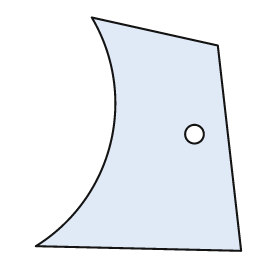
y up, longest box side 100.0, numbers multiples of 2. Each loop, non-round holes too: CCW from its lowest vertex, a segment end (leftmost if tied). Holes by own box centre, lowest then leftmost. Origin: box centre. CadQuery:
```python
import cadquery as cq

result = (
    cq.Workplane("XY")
    .moveTo(44.0, -50.0)
    .lineTo(34.0, 38.0)
    .lineTo(-20.0, 50.0)
    .threePointArc((-12.0, -4.0), (-44.0, -48.0))
    .close()
    .moveTo(24.0, 0.0)
    .circle(4.0)
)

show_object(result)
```